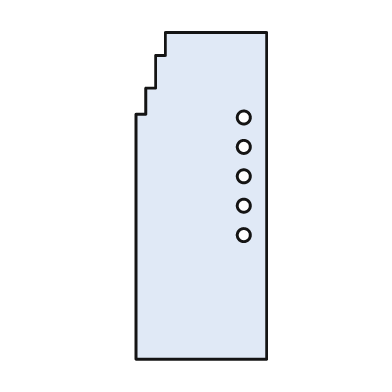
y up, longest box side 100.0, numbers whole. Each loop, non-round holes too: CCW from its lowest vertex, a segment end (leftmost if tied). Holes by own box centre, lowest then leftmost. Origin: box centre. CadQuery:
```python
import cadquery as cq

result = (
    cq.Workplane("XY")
    .moveTo(-20.0, -50.0)
    .lineTo(20.0, -50.0)
    .lineTo(20.0, 50.0)
    .lineTo(-11.0, 50.0)
    .lineTo(-11.0, 43.0)
    .lineTo(-14.0, 43.0)
    .lineTo(-14.0, 33.0)
    .lineTo(-17.0, 33.0)
    .lineTo(-17.0, 25.0)
    .lineTo(-20.0, 25.0)
    .close()
    .moveTo(13.0, -12.0)
    .circle(2.0)
    .moveTo(13.0, -3.0)
    .circle(2.0)
    .moveTo(13.0, 6.0)
    .circle(2.0)
    .moveTo(13.0, 15.0)
    .circle(2.0)
    .moveTo(13.0, 24.0)
    .circle(2.0)
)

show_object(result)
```